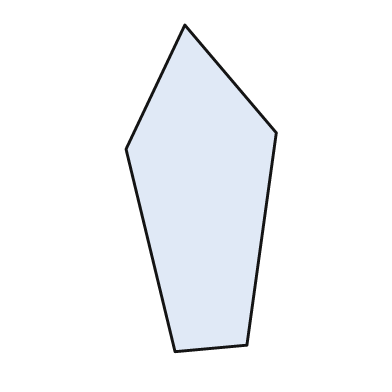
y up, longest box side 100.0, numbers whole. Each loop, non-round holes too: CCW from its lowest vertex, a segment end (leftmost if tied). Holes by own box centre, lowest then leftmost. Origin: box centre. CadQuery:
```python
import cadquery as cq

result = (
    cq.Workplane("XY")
    .moveTo(-8.0, -50.0)
    .lineTo(14.0, -48.0)
    .lineTo(23.0, 17.0)
    .lineTo(-5.0, 50.0)
    .lineTo(-23.0, 12.0)
    .close()
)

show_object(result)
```